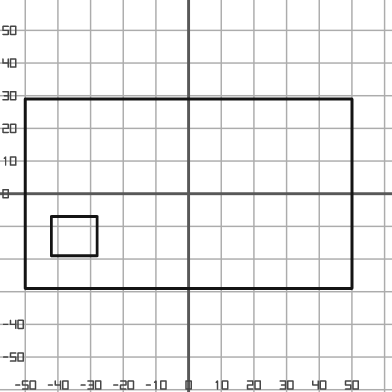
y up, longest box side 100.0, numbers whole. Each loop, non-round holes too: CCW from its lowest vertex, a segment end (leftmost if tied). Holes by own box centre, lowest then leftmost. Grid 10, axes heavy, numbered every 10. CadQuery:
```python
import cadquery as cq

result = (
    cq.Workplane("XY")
    .moveTo(-50.0, -29.0)
    .lineTo(50.0, -29.0)
    .lineTo(50.0, 29.0)
    .lineTo(-50.0, 29.0)
    .close()
    .moveTo(-42.0, -19.0)
    .lineTo(-28.0, -19.0)
    .lineTo(-28.0, -7.0)
    .lineTo(-42.0, -7.0)
    .close()
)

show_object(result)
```